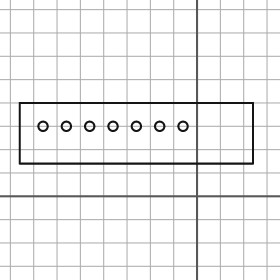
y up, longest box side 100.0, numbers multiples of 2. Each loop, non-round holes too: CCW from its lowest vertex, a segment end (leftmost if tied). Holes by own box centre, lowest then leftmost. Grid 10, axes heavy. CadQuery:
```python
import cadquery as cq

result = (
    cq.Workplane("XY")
    .moveTo(-76.0, 14.0)
    .lineTo(24.0, 14.0)
    .lineTo(24.0, 40.0)
    .lineTo(-76.0, 40.0)
    .close()
    .moveTo(-66.0, 30.0)
    .circle(2.0)
    .moveTo(-56.0, 30.0)
    .circle(2.0)
    .moveTo(-46.0, 30.0)
    .circle(2.0)
    .moveTo(-36.0, 30.0)
    .circle(2.0)
    .moveTo(-26.0, 30.0)
    .circle(2.0)
    .moveTo(-16.0, 30.0)
    .circle(2.0)
    .moveTo(-6.0, 30.0)
    .circle(2.0)
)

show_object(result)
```